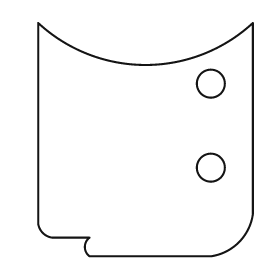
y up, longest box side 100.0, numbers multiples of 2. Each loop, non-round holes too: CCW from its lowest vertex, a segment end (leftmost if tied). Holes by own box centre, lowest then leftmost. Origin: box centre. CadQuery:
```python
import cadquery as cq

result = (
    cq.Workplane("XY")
    .moveTo(-24.0, -50.0)
    .lineTo(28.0, -50.0)
    .threePointArc((40.0, -44.0), (46.0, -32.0))
    .lineTo(46.0, 50.0)
    .threePointArc((0.0, 32.0), (-46.0, 50.0))
    .lineTo(-46.0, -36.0)
    .threePointArc((-44.0, -40.0), (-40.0, -42.0))
    .lineTo(-24.0, -42.0)
    .threePointArc((-26.0, -46.0), (-24.0, -50.0))
    .close()
    .moveTo(28.0, -12.0)
    .circle(6.0)
    .moveTo(28.0, 24.0)
    .circle(6.0)
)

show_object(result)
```